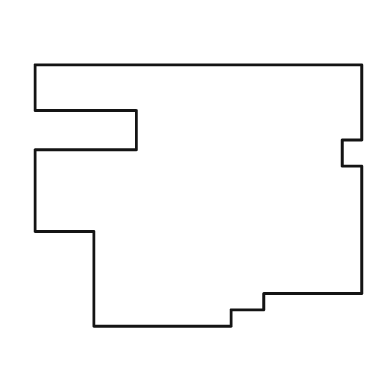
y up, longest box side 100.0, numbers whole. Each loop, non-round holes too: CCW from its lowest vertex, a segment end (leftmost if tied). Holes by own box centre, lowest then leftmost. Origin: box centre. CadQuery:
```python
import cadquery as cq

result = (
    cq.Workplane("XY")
    .moveTo(-32.0, -40.0)
    .lineTo(10.0, -40.0)
    .lineTo(10.0, -35.0)
    .lineTo(20.0, -35.0)
    .lineTo(20.0, -30.0)
    .lineTo(50.0, -30.0)
    .lineTo(50.0, 9.0)
    .lineTo(44.0, 9.0)
    .lineTo(44.0, 17.0)
    .lineTo(50.0, 17.0)
    .lineTo(50.0, 40.0)
    .lineTo(-50.0, 40.0)
    .lineTo(-50.0, 26.0)
    .lineTo(-19.0, 26.0)
    .lineTo(-19.0, 14.0)
    .lineTo(-50.0, 14.0)
    .lineTo(-50.0, -11.0)
    .lineTo(-32.0, -11.0)
    .close()
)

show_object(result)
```